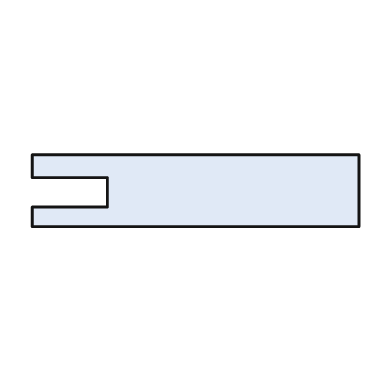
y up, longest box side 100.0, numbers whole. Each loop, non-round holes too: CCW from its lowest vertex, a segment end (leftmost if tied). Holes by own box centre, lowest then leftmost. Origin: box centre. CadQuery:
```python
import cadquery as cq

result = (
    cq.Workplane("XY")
    .moveTo(-50.0, -11.0)
    .lineTo(50.0, -11.0)
    .lineTo(50.0, 11.0)
    .lineTo(-50.0, 11.0)
    .lineTo(-50.0, 4.0)
    .lineTo(-27.0, 4.0)
    .lineTo(-27.0, -5.0)
    .lineTo(-50.0, -5.0)
    .close()
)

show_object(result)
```